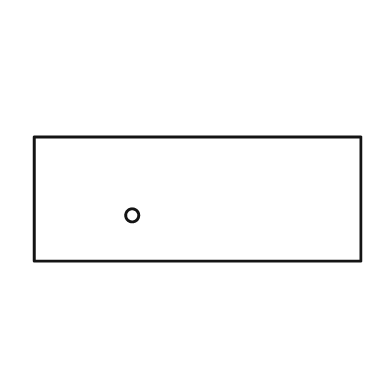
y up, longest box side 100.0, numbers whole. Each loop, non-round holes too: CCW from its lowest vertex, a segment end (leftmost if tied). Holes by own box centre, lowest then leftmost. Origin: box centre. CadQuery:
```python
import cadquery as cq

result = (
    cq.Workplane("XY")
    .moveTo(-50.0, -19.0)
    .lineTo(50.0, -19.0)
    .lineTo(50.0, 19.0)
    .lineTo(-50.0, 19.0)
    .close()
    .moveTo(-20.0, -5.0)
    .circle(2.0)
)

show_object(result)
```